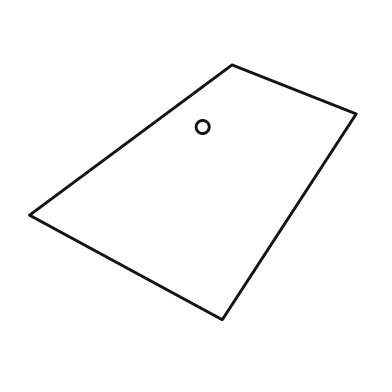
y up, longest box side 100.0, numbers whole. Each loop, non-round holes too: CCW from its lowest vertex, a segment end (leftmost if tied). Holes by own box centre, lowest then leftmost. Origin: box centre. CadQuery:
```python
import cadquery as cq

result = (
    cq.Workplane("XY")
    .moveTo(9.0, -39.0)
    .lineTo(50.0, 24.0)
    .lineTo(12.0, 39.0)
    .lineTo(-50.0, -7.0)
    .close()
    .moveTo(3.0, 20.0)
    .circle(2.0)
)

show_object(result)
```